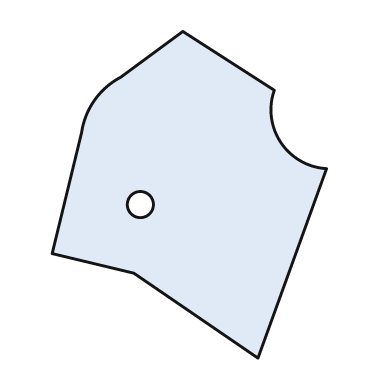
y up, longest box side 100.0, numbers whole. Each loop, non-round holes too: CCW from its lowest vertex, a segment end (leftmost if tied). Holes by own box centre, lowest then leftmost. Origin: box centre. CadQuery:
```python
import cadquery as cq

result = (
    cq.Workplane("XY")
    .moveTo(21.0, -50.0)
    .lineTo(42.0, 8.0)
    .threePointArc((28.0, 16.0), (26.0, 32.0))
    .lineTo(-2.0, 50.0)
    .lineTo(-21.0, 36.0)
    .threePointArc((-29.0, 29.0), (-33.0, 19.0))
    .lineTo(-42.0, -18.0)
    .lineTo(-17.0, -24.0)
    .close()
    .moveTo(-15.0, -3.0)
    .circle(4.0)
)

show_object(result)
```